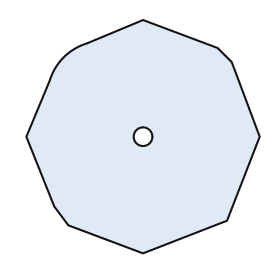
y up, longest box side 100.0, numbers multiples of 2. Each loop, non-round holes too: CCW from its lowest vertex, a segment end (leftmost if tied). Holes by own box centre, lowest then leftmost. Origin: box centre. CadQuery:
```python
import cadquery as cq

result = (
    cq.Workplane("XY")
    .moveTo(0.0, -50.0)
    .lineTo(36.0, -36.0)
    .lineTo(50.0, 0.0)
    .lineTo(38.0, 32.0)
    .lineTo(32.0, 38.0)
    .lineTo(0.0, 50.0)
    .lineTo(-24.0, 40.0)
    .threePointArc((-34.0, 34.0), (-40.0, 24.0))
    .lineTo(-50.0, 0.0)
    .lineTo(-38.0, -30.0)
    .lineTo(-32.0, -38.0)
    .close()
    .moveTo(0.0, 0.0)
    .circle(4.0)
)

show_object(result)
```